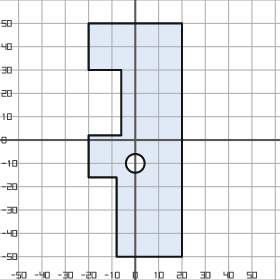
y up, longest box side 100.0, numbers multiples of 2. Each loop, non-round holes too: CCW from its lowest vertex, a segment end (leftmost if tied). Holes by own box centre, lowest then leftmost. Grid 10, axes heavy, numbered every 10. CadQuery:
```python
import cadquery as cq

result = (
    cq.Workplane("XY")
    .moveTo(-8.0, -50.0)
    .lineTo(20.0, -50.0)
    .lineTo(20.0, 50.0)
    .lineTo(-20.0, 50.0)
    .lineTo(-20.0, 30.0)
    .lineTo(-6.0, 30.0)
    .lineTo(-6.0, 2.0)
    .lineTo(-20.0, 2.0)
    .lineTo(-20.0, -16.0)
    .lineTo(-8.0, -16.0)
    .close()
    .moveTo(0.0, -10.0)
    .circle(4.0)
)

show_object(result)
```